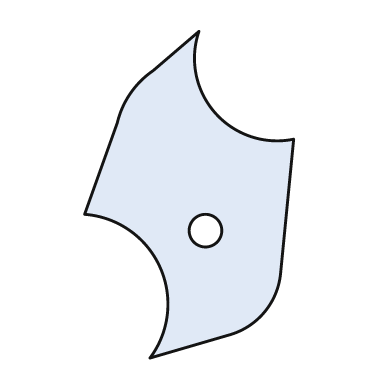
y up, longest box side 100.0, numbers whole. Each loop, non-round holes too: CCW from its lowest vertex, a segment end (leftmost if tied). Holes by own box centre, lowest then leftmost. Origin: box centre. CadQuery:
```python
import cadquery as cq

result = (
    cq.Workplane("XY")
    .moveTo(-12.0, -50.0)
    .lineTo(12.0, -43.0)
    .threePointArc((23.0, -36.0), (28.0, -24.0))
    .lineTo(32.0, 17.0)
    .threePointArc((8.0, 25.0), (3.0, 50.0))
    .lineTo(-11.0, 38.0)
    .threePointArc((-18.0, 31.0), (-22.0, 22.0))
    .lineTo(-32.0, -6.0)
    .threePointArc((-9.0, -22.0), (-12.0, -50.0))
    .close()
    .moveTo(5.0, -11.0)
    .circle(5.0)
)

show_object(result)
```